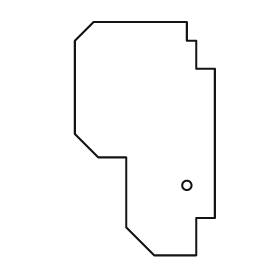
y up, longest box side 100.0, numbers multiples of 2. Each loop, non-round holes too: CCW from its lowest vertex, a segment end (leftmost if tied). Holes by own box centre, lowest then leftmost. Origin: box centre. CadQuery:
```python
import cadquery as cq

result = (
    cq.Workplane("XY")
    .moveTo(4.0, -50.0)
    .lineTo(22.0, -50.0)
    .lineTo(22.0, -34.0)
    .lineTo(30.0, -34.0)
    .lineTo(30.0, 30.0)
    .lineTo(22.0, 30.0)
    .lineTo(22.0, 42.0)
    .lineTo(18.0, 42.0)
    .lineTo(18.0, 50.0)
    .lineTo(-22.0, 50.0)
    .lineTo(-30.0, 42.0)
    .lineTo(-30.0, 2.0)
    .lineTo(-20.0, -8.0)
    .lineTo(-8.0, -8.0)
    .lineTo(-8.0, -38.0)
    .close()
    .moveTo(18.0, -20.0)
    .circle(2.0)
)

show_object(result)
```